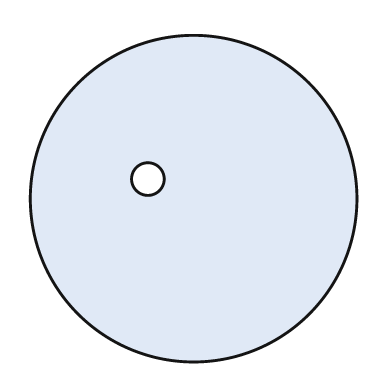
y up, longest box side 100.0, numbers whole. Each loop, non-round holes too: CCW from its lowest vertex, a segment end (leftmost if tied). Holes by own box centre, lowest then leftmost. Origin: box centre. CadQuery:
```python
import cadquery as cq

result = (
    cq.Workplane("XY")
    .moveTo(0.0, 0.0)
    .circle(50.0)
    .moveTo(-14.0, 6.0)
    .circle(5.0)
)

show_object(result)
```